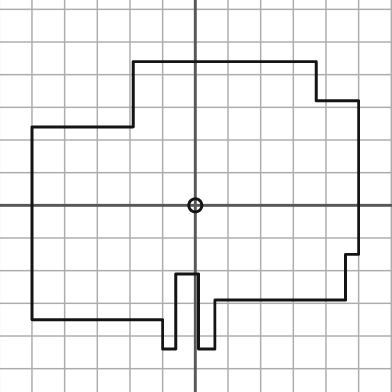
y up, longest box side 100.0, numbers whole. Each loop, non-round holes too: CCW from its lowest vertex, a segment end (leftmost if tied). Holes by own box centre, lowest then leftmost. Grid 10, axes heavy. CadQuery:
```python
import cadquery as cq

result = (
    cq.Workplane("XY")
    .moveTo(-10.0, -44.0)
    .lineTo(-6.0, -44.0)
    .lineTo(-6.0, -21.0)
    .lineTo(1.0, -21.0)
    .lineTo(1.0, -44.0)
    .lineTo(6.0, -44.0)
    .lineTo(6.0, -29.0)
    .lineTo(46.0, -29.0)
    .lineTo(46.0, -15.0)
    .lineTo(50.0, -15.0)
    .lineTo(50.0, 32.0)
    .lineTo(37.0, 32.0)
    .lineTo(37.0, 44.0)
    .lineTo(-19.0, 44.0)
    .lineTo(-19.0, 24.0)
    .lineTo(-50.0, 24.0)
    .lineTo(-50.0, -35.0)
    .lineTo(-10.0, -35.0)
    .close()
    .moveTo(0.0, 0.0)
    .circle(2.0)
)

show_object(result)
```